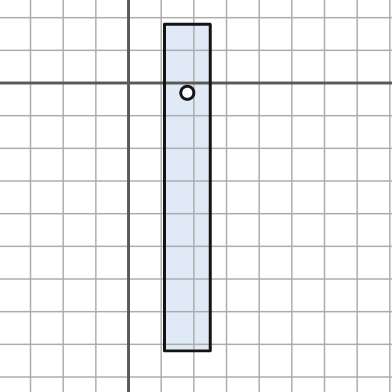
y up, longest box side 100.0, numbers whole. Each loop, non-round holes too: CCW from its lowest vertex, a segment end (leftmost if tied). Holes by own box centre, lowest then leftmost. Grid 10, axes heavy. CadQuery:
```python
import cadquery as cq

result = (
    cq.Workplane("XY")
    .moveTo(11.0, -82.0)
    .lineTo(25.0, -82.0)
    .lineTo(25.0, 18.0)
    .lineTo(11.0, 18.0)
    .close()
    .moveTo(18.0, -3.0)
    .circle(2.0)
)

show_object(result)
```